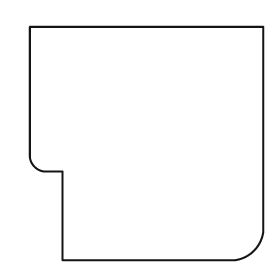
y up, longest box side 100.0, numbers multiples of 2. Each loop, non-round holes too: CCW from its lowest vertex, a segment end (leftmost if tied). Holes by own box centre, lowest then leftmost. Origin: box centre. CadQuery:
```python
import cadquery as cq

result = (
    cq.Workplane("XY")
    .moveTo(-36.0, -50.0)
    .lineTo(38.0, -50.0)
    .threePointArc((46.0, -46.0), (50.0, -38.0))
    .lineTo(50.0, 50.0)
    .lineTo(-50.0, 50.0)
    .lineTo(-50.0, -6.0)
    .threePointArc((-48.0, -10.0), (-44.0, -12.0))
    .lineTo(-36.0, -12.0)
    .close()
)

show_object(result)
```